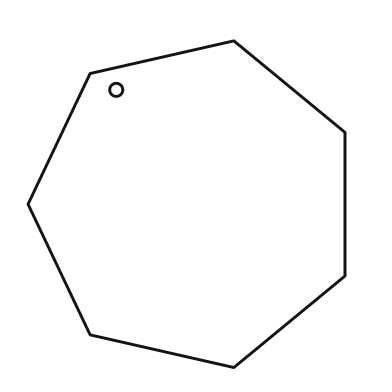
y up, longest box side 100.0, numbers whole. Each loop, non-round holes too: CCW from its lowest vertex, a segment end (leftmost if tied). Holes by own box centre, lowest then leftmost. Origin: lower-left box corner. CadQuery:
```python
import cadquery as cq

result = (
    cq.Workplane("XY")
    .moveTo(63.0, 0.0)
    .lineTo(97.0, 28.0)
    .lineTo(97.0, 72.0)
    .lineTo(63.0, 100.0)
    .lineTo(19.0, 90.0)
    .lineTo(0.0, 50.0)
    .lineTo(19.0, 10.0)
    .close()
    .moveTo(27.0, 85.0)
    .circle(2.0)
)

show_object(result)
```